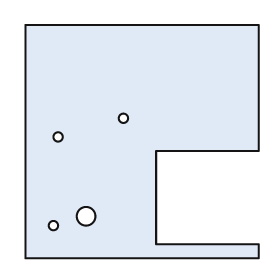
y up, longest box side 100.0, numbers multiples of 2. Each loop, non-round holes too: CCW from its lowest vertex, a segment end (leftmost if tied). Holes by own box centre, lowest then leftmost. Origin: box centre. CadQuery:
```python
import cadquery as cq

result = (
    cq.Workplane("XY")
    .moveTo(-50.0, -50.0)
    .lineTo(50.0, -50.0)
    .lineTo(50.0, -44.0)
    .lineTo(6.0, -44.0)
    .lineTo(6.0, -4.0)
    .lineTo(50.0, -4.0)
    .lineTo(50.0, 50.0)
    .lineTo(-50.0, 50.0)
    .close()
    .moveTo(-38.0, -36.0)
    .circle(2.0)
    .moveTo(-24.0, -32.0)
    .circle(4.0)
    .moveTo(-36.0, 2.0)
    .circle(2.0)
    .moveTo(-8.0, 10.0)
    .circle(2.0)
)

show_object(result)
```